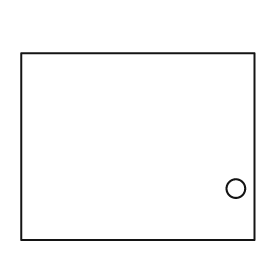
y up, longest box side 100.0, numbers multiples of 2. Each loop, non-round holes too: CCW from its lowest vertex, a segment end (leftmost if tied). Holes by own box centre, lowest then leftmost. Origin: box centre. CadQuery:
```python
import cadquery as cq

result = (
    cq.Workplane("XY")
    .moveTo(-50.0, -40.0)
    .lineTo(50.0, -40.0)
    .lineTo(50.0, 40.0)
    .lineTo(-50.0, 40.0)
    .close()
    .moveTo(42.0, -18.0)
    .circle(4.0)
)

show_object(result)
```